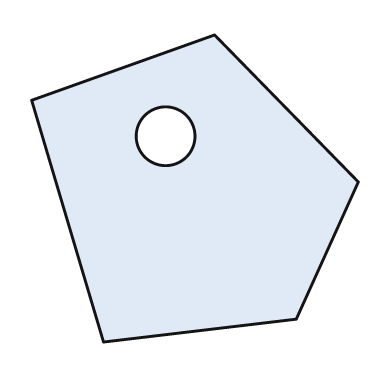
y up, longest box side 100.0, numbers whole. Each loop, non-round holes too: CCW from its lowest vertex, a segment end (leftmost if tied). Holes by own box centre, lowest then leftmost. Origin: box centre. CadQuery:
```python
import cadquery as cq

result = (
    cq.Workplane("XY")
    .moveTo(-28.0, -47.0)
    .lineTo(31.0, -40.0)
    .lineTo(50.0, 2.0)
    .lineTo(6.0, 47.0)
    .lineTo(-50.0, 27.0)
    .close()
    .moveTo(-9.0, 16.0)
    .circle(9.0)
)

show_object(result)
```